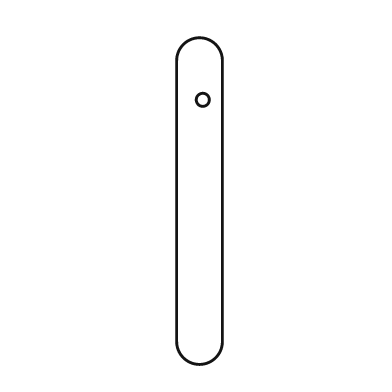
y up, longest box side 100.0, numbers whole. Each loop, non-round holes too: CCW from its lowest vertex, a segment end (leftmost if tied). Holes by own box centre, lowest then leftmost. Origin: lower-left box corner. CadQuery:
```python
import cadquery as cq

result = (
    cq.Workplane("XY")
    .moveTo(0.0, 7.0)
    .threePointArc((7.0, 0.0), (14.0, 7.0))
    .lineTo(14.0, 93.0)
    .threePointArc((7.0, 100.0), (0.0, 93.0))
    .close()
    .moveTo(8.0, 81.0)
    .circle(2.0)
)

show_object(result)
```